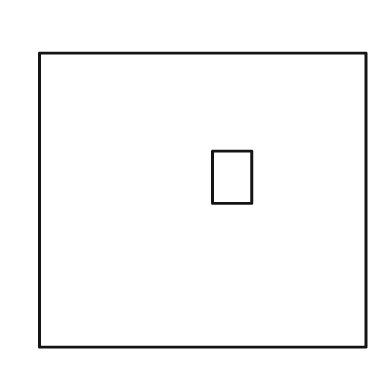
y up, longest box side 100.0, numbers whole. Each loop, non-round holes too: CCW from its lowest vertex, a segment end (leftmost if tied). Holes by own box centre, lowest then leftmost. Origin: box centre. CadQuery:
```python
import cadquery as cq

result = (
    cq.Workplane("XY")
    .moveTo(-50.0, -45.0)
    .lineTo(50.0, -45.0)
    .lineTo(50.0, 45.0)
    .lineTo(-50.0, 45.0)
    .close()
    .moveTo(3.0, -1.0)
    .lineTo(15.0, -1.0)
    .lineTo(15.0, 15.0)
    .lineTo(3.0, 15.0)
    .close()
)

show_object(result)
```